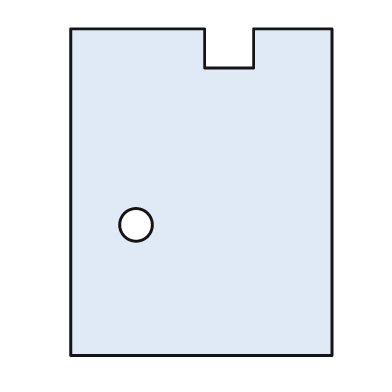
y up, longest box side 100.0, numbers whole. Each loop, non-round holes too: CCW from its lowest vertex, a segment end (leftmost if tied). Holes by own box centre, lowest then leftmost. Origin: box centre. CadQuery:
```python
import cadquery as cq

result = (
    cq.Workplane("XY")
    .moveTo(-40.0, -50.0)
    .lineTo(40.0, -50.0)
    .lineTo(40.0, 50.0)
    .lineTo(16.0, 50.0)
    .lineTo(16.0, 38.0)
    .lineTo(1.0, 38.0)
    .lineTo(1.0, 50.0)
    .lineTo(-40.0, 50.0)
    .close()
    .moveTo(-20.0, -10.0)
    .circle(5.0)
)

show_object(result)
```